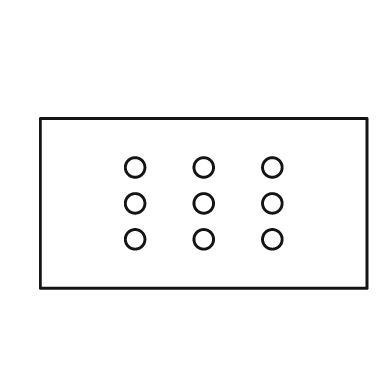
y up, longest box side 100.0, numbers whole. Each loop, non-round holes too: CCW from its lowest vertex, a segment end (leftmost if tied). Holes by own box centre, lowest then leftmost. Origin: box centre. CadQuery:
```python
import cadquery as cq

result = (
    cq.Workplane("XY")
    .moveTo(-50.0, -26.0)
    .lineTo(50.0, -26.0)
    .lineTo(50.0, 26.0)
    .lineTo(-50.0, 26.0)
    .close()
    .moveTo(-21.0, -11.0)
    .circle(3.0)
    .moveTo(0.0, -11.0)
    .circle(3.0)
    .moveTo(21.0, -11.0)
    .circle(3.0)
    .moveTo(-21.0, 0.0)
    .circle(3.0)
    .moveTo(0.0, 0.0)
    .circle(3.0)
    .moveTo(21.0, 0.0)
    .circle(3.0)
    .moveTo(-21.0, 11.0)
    .circle(3.0)
    .moveTo(0.0, 11.0)
    .circle(3.0)
    .moveTo(21.0, 11.0)
    .circle(3.0)
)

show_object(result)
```